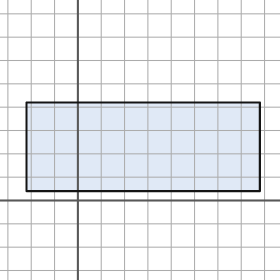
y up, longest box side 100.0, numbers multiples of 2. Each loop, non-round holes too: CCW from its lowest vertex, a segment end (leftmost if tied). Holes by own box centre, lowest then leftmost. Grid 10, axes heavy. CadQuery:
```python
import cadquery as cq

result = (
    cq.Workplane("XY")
    .moveTo(-22.0, 4.0)
    .lineTo(78.0, 4.0)
    .lineTo(78.0, 42.0)
    .lineTo(-22.0, 42.0)
    .close()
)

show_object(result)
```